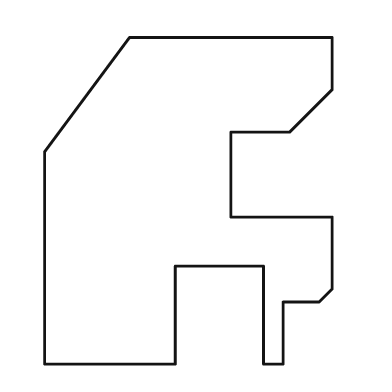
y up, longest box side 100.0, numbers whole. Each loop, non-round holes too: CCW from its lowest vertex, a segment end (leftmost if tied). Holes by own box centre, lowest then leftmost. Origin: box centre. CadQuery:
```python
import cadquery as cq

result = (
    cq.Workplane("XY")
    .moveTo(-44.0, -50.0)
    .lineTo(-4.0, -50.0)
    .lineTo(-4.0, -20.0)
    .lineTo(23.0, -20.0)
    .lineTo(23.0, -50.0)
    .lineTo(29.0, -50.0)
    .lineTo(29.0, -31.0)
    .lineTo(40.0, -31.0)
    .lineTo(44.0, -27.0)
    .lineTo(44.0, -5.0)
    .lineTo(13.0, -5.0)
    .lineTo(13.0, 21.0)
    .lineTo(31.0, 21.0)
    .lineTo(44.0, 34.0)
    .lineTo(44.0, 50.0)
    .lineTo(-18.0, 50.0)
    .lineTo(-44.0, 15.0)
    .close()
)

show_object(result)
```